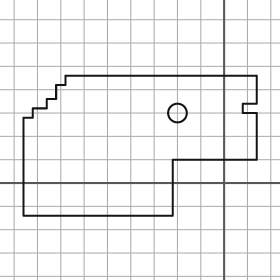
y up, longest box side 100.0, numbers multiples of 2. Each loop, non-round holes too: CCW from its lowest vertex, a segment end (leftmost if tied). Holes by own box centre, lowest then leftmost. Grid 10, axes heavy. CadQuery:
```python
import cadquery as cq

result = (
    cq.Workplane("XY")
    .moveTo(-86.0, -14.0)
    .lineTo(-22.0, -14.0)
    .lineTo(-22.0, 10.0)
    .lineTo(14.0, 10.0)
    .lineTo(14.0, 30.0)
    .lineTo(8.0, 30.0)
    .lineTo(8.0, 34.0)
    .lineTo(14.0, 34.0)
    .lineTo(14.0, 46.0)
    .lineTo(-68.0, 46.0)
    .lineTo(-68.0, 42.0)
    .lineTo(-72.0, 42.0)
    .lineTo(-72.0, 36.0)
    .lineTo(-76.0, 36.0)
    .lineTo(-76.0, 32.0)
    .lineTo(-82.0, 32.0)
    .lineTo(-82.0, 28.0)
    .lineTo(-86.0, 28.0)
    .close()
    .moveTo(-20.0, 30.0)
    .circle(4.0)
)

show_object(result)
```